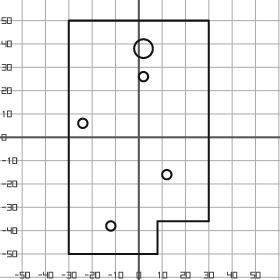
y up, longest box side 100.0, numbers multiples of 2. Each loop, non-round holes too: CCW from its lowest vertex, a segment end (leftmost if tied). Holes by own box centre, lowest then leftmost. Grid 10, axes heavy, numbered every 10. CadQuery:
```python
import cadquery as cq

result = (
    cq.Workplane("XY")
    .moveTo(-30.0, -50.0)
    .lineTo(8.0, -50.0)
    .lineTo(8.0, -36.0)
    .lineTo(30.0, -36.0)
    .lineTo(30.0, 50.0)
    .lineTo(-30.0, 50.0)
    .close()
    .moveTo(-12.0, -38.0)
    .circle(2.0)
    .moveTo(12.0, -16.0)
    .circle(2.0)
    .moveTo(-24.0, 6.0)
    .circle(2.0)
    .moveTo(2.0, 26.0)
    .circle(2.0)
    .moveTo(2.0, 38.0)
    .circle(4.0)
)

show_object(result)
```